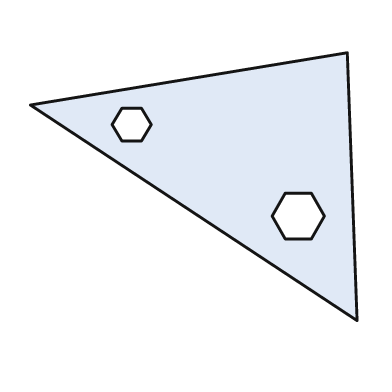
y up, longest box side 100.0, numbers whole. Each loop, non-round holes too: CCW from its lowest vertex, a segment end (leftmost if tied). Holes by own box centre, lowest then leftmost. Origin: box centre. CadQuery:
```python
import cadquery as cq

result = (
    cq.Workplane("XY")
    .moveTo(50.0, -41.0)
    .lineTo(47.0, 41.0)
    .lineTo(-50.0, 25.0)
    .close()
    .moveTo(28.0, -16.0)
    .lineTo(36.0, -16.0)
    .lineTo(40.0, -9.0)
    .lineTo(36.0, -2.0)
    .lineTo(28.0, -2.0)
    .lineTo(24.0, -9.0)
    .close()
    .moveTo(-22.0, 14.0)
    .lineTo(-16.0, 14.0)
    .lineTo(-13.0, 19.0)
    .lineTo(-16.0, 24.0)
    .lineTo(-22.0, 24.0)
    .lineTo(-25.0, 19.0)
    .close()
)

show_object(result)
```